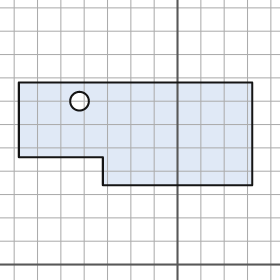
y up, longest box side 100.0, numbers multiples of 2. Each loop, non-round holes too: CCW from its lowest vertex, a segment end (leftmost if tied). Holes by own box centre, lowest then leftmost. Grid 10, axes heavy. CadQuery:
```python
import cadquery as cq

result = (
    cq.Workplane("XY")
    .moveTo(-32.0, 34.0)
    .lineTo(32.0, 34.0)
    .lineTo(32.0, 78.0)
    .lineTo(-68.0, 78.0)
    .lineTo(-68.0, 46.0)
    .lineTo(-32.0, 46.0)
    .close()
    .moveTo(-42.0, 70.0)
    .circle(4.0)
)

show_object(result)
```